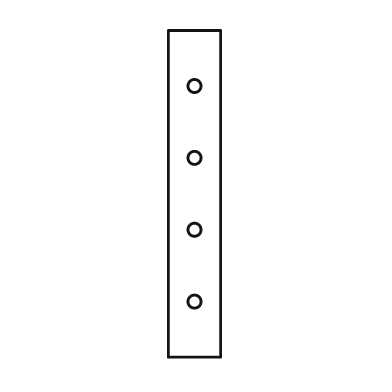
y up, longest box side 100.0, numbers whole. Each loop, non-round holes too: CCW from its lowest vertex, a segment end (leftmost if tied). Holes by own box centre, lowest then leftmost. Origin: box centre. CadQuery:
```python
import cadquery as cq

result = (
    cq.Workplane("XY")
    .moveTo(-8.0, -50.0)
    .lineTo(8.0, -50.0)
    .lineTo(8.0, 50.0)
    .lineTo(-8.0, 50.0)
    .close()
    .moveTo(0.0, -33.0)
    .circle(2.0)
    .moveTo(0.0, -11.0)
    .circle(2.0)
    .moveTo(0.0, 11.0)
    .circle(2.0)
    .moveTo(0.0, 33.0)
    .circle(2.0)
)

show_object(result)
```